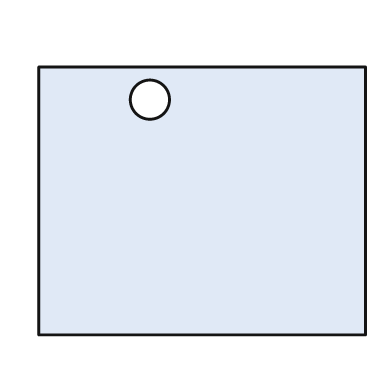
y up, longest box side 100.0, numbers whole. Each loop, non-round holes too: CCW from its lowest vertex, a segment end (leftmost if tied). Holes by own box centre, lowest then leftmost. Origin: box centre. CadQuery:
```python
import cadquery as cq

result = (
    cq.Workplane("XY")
    .moveTo(-50.0, -41.0)
    .lineTo(50.0, -41.0)
    .lineTo(50.0, 41.0)
    .lineTo(-50.0, 41.0)
    .close()
    .moveTo(-16.0, 31.0)
    .circle(6.0)
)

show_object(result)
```